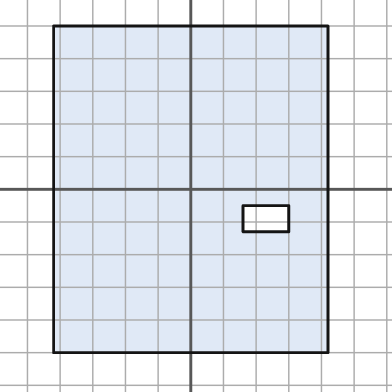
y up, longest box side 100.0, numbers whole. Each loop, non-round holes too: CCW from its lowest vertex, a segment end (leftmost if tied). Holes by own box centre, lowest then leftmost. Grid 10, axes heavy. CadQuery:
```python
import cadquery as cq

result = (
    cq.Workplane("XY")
    .moveTo(-42.0, -50.0)
    .lineTo(42.0, -50.0)
    .lineTo(42.0, 50.0)
    .lineTo(-42.0, 50.0)
    .close()
    .moveTo(16.0, -13.0)
    .lineTo(30.0, -13.0)
    .lineTo(30.0, -5.0)
    .lineTo(16.0, -5.0)
    .close()
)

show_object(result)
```